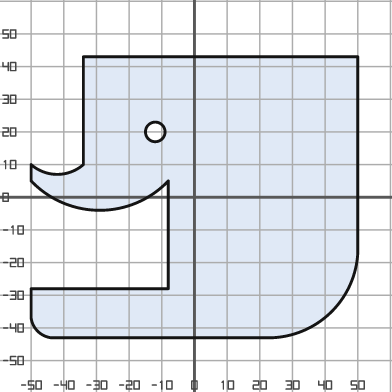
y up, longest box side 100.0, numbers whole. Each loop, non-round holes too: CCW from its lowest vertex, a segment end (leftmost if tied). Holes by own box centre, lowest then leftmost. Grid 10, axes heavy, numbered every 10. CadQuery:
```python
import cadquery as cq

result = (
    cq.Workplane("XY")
    .moveTo(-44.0, -43.0)
    .lineTo(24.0, -43.0)
    .threePointArc((42.0, -35.0), (50.0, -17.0))
    .lineTo(50.0, 43.0)
    .lineTo(-34.0, 43.0)
    .lineTo(-34.0, 10.0)
    .threePointArc((-42.0, 7.0), (-50.0, 10.0))
    .lineTo(-50.0, 5.0)
    .threePointArc((-29.0, -4.0), (-8.0, 5.0))
    .lineTo(-8.0, -28.0)
    .lineTo(-50.0, -28.0)
    .lineTo(-50.0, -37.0)
    .threePointArc((-48.0, -41.0), (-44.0, -43.0))
    .close()
    .moveTo(-12.0, 20.0)
    .circle(3.0)
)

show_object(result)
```